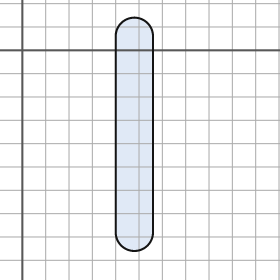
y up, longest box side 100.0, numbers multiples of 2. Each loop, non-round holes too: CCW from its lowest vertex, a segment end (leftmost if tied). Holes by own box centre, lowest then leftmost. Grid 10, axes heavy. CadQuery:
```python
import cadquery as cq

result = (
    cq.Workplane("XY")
    .moveTo(40.0, -78.0)
    .threePointArc((48.0, -86.0), (56.0, -78.0))
    .lineTo(56.0, 6.0)
    .threePointArc((48.0, 14.0), (40.0, 6.0))
    .close()
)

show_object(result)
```